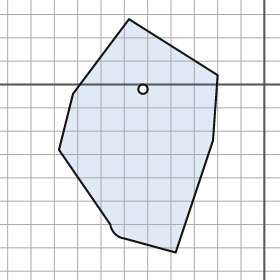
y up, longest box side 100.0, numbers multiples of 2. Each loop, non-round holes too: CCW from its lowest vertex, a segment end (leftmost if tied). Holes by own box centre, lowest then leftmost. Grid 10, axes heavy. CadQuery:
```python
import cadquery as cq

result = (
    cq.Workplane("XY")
    .moveTo(-38.0, -72.0)
    .lineTo(-22.0, -24.0)
    .lineTo(-20.0, 4.0)
    .lineTo(-58.0, 28.0)
    .lineTo(-82.0, -4.0)
    .lineTo(-88.0, -28.0)
    .lineTo(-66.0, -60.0)
    .threePointArc((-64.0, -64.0), (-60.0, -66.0))
    .close()
    .moveTo(-52.0, -2.0)
    .circle(2.0)
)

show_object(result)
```